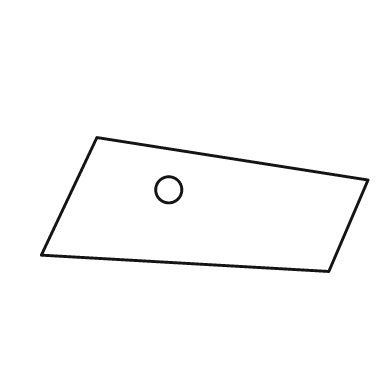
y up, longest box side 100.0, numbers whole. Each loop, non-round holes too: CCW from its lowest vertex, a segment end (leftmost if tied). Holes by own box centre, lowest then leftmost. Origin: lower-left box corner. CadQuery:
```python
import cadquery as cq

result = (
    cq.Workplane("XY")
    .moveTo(88.0, 0.0)
    .lineTo(100.0, 28.0)
    .lineTo(17.0, 41.0)
    .lineTo(0.0, 5.0)
    .close()
    .moveTo(39.0, 25.0)
    .circle(4.0)
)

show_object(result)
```